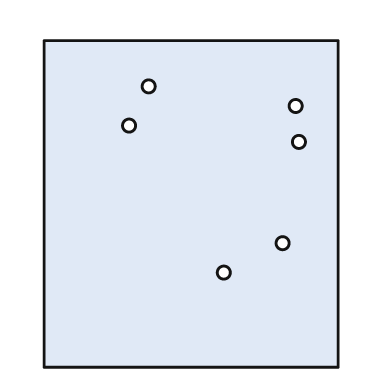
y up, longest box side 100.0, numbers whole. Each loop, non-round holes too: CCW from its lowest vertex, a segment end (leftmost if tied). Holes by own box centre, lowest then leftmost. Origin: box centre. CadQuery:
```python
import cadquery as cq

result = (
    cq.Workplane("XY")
    .moveTo(-45.0, -50.0)
    .lineTo(45.0, -50.0)
    .lineTo(45.0, 50.0)
    .lineTo(-45.0, 50.0)
    .close()
    .moveTo(10.0, -21.0)
    .circle(2.0)
    .moveTo(28.0, -12.0)
    .circle(2.0)
    .moveTo(33.0, 19.0)
    .circle(2.0)
    .moveTo(-19.0, 24.0)
    .circle(2.0)
    .moveTo(32.0, 30.0)
    .circle(2.0)
    .moveTo(-13.0, 36.0)
    .circle(2.0)
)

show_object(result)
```